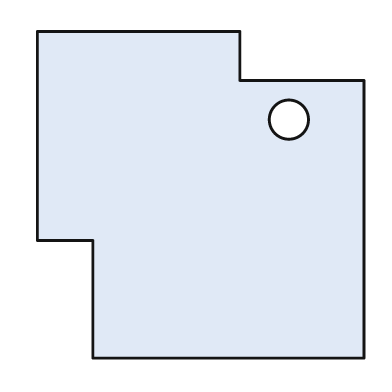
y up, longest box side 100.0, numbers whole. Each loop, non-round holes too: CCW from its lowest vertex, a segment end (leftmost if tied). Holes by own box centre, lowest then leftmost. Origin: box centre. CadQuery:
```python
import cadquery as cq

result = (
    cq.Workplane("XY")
    .moveTo(-33.0, -50.0)
    .lineTo(50.0, -50.0)
    .lineTo(50.0, 35.0)
    .lineTo(12.0, 35.0)
    .lineTo(12.0, 50.0)
    .lineTo(-50.0, 50.0)
    .lineTo(-50.0, -14.0)
    .lineTo(-33.0, -14.0)
    .close()
    .moveTo(27.0, 23.0)
    .circle(6.0)
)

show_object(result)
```